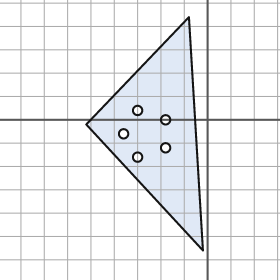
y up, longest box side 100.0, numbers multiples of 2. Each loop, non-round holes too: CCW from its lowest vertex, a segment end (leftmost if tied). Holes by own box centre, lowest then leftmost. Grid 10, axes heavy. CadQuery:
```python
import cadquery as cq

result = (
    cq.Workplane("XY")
    .moveTo(-2.0, -56.0)
    .lineTo(-8.0, 44.0)
    .lineTo(-52.0, -2.0)
    .close()
    .moveTo(-30.0, -16.0)
    .circle(2.0)
    .moveTo(-18.0, -12.0)
    .circle(2.0)
    .moveTo(-36.0, -6.0)
    .circle(2.0)
    .moveTo(-18.0, 0.0)
    .circle(2.0)
    .moveTo(-30.0, 4.0)
    .circle(2.0)
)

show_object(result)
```